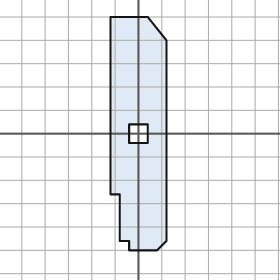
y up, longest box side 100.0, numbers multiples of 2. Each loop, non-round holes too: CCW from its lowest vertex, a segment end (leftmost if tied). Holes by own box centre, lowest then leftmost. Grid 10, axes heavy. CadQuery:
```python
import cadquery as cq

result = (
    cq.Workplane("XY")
    .moveTo(-4.0, -50.0)
    .lineTo(8.0, -50.0)
    .lineTo(12.0, -46.0)
    .lineTo(12.0, 40.0)
    .lineTo(4.0, 50.0)
    .lineTo(-12.0, 50.0)
    .lineTo(-12.0, -26.0)
    .lineTo(-8.0, -26.0)
    .lineTo(-8.0, -46.0)
    .lineTo(-4.0, -46.0)
    .close()
    .moveTo(-4.0, -4.0)
    .lineTo(4.0, -4.0)
    .lineTo(4.0, 4.0)
    .lineTo(-4.0, 4.0)
    .close()
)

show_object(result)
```